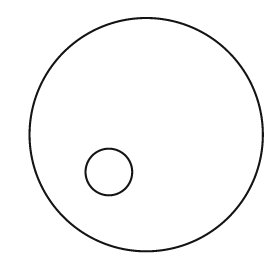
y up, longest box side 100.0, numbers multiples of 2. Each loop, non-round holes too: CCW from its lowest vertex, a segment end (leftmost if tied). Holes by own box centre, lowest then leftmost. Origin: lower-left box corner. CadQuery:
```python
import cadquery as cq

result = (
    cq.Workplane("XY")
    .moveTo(50.0, 50.0)
    .circle(50.0)
    .moveTo(34.0, 34.0)
    .circle(10.0)
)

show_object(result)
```